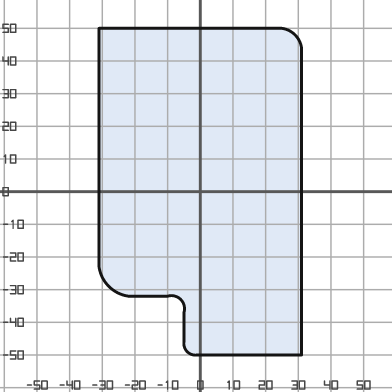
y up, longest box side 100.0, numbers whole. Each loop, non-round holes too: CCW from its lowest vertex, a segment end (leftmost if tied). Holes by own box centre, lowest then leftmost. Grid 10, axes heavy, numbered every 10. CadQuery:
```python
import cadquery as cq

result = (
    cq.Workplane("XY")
    .moveTo(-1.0, -50.0)
    .lineTo(31.0, -50.0)
    .lineTo(31.0, 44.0)
    .threePointArc((29.0, 48.0), (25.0, 50.0))
    .lineTo(-31.0, 50.0)
    .lineTo(-31.0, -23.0)
    .threePointArc((-28.0, -29.0), (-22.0, -32.0))
    .lineTo(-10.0, -32.0)
    .threePointArc((-6.0, -33.0), (-5.0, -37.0))
    .lineTo(-5.0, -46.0)
    .threePointArc((-4.0, -49.0), (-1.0, -50.0))
    .close()
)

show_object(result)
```